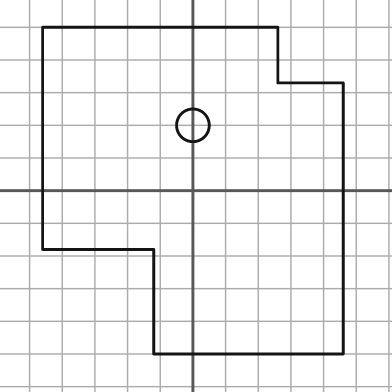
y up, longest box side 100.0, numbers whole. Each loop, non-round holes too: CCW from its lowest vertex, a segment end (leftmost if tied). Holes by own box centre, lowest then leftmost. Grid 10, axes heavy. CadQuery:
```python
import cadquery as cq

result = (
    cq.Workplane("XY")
    .moveTo(-12.0, -50.0)
    .lineTo(46.0, -50.0)
    .lineTo(46.0, 33.0)
    .lineTo(26.0, 33.0)
    .lineTo(26.0, 50.0)
    .lineTo(-46.0, 50.0)
    .lineTo(-46.0, -18.0)
    .lineTo(-12.0, -18.0)
    .close()
    .moveTo(0.0, 20.0)
    .circle(5.0)
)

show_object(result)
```